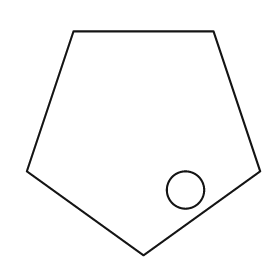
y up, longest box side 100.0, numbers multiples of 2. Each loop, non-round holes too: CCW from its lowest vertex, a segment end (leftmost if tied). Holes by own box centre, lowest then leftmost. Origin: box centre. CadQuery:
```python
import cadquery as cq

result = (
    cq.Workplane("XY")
    .moveTo(0.0, -48.0)
    .lineTo(50.0, -12.0)
    .lineTo(30.0, 48.0)
    .lineTo(-30.0, 48.0)
    .lineTo(-50.0, -12.0)
    .close()
    .moveTo(18.0, -20.0)
    .circle(8.0)
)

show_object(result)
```